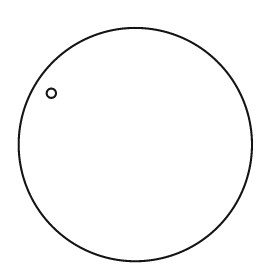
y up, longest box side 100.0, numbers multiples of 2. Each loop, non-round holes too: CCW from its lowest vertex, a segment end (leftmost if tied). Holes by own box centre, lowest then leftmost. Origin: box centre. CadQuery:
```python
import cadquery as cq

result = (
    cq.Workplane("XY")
    .moveTo(0.0, 0.0)
    .circle(50.0)
    .moveTo(-36.0, 22.0)
    .circle(2.0)
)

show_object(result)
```